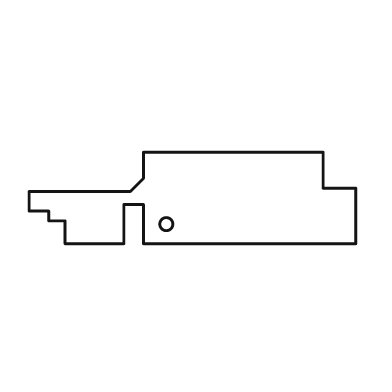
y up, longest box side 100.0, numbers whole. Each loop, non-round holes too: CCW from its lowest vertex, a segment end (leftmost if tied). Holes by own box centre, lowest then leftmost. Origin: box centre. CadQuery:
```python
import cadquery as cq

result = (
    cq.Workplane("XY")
    .moveTo(-39.0, -14.0)
    .lineTo(-21.0, -14.0)
    .lineTo(-21.0, -2.0)
    .lineTo(-15.0, -2.0)
    .lineTo(-15.0, -14.0)
    .lineTo(50.0, -14.0)
    .lineTo(50.0, 3.0)
    .lineTo(40.0, 3.0)
    .lineTo(40.0, 14.0)
    .lineTo(-15.0, 14.0)
    .lineTo(-15.0, 6.0)
    .lineTo(-19.0, 2.0)
    .lineTo(-50.0, 2.0)
    .lineTo(-50.0, -4.0)
    .lineTo(-44.0, -4.0)
    .lineTo(-44.0, -7.0)
    .lineTo(-39.0, -7.0)
    .close()
    .moveTo(-8.0, -8.0)
    .circle(2.0)
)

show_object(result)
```